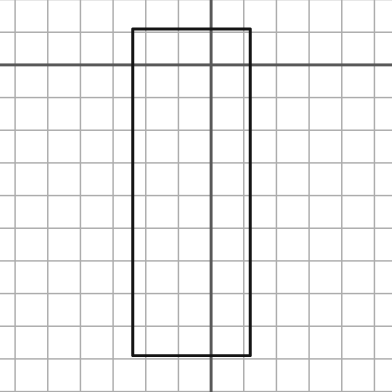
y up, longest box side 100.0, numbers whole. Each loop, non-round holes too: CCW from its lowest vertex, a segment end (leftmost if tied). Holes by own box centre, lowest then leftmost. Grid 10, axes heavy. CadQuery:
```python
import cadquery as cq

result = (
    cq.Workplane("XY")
    .moveTo(-24.0, -89.0)
    .lineTo(12.0, -89.0)
    .lineTo(12.0, 11.0)
    .lineTo(-24.0, 11.0)
    .close()
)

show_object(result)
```